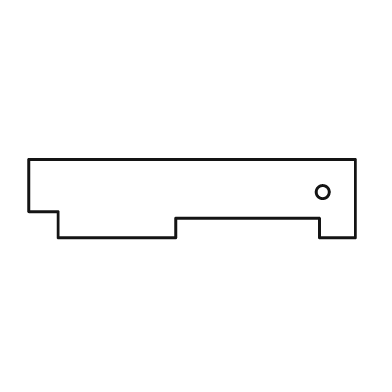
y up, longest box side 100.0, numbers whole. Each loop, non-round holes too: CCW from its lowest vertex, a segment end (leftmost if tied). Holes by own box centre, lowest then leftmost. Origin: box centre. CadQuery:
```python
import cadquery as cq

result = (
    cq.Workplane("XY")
    .moveTo(-41.0, -12.0)
    .lineTo(-5.0, -12.0)
    .lineTo(-5.0, -6.0)
    .lineTo(39.0, -6.0)
    .lineTo(39.0, -12.0)
    .lineTo(50.0, -12.0)
    .lineTo(50.0, 12.0)
    .lineTo(-50.0, 12.0)
    .lineTo(-50.0, -4.0)
    .lineTo(-41.0, -4.0)
    .close()
    .moveTo(40.0, 2.0)
    .circle(2.0)
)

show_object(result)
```